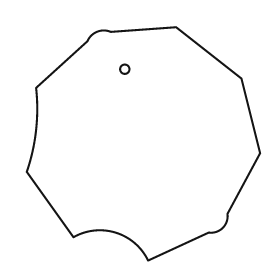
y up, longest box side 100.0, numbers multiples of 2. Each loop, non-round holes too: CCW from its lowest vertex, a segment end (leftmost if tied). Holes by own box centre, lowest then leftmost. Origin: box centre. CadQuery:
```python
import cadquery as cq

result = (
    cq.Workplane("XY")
    .moveTo(2.0, -50.0)
    .lineTo(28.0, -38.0)
    .threePointArc((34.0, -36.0), (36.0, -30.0))
    .lineTo(50.0, -4.0)
    .lineTo(42.0, 28.0)
    .lineTo(14.0, 50.0)
    .lineTo(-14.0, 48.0)
    .threePointArc((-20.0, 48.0), (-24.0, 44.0))
    .lineTo(-46.0, 24.0)
    .threePointArc((-46.0, 6.0), (-50.0, -12.0))
    .lineTo(-30.0, -40.0)
    .threePointArc((-12.0, -38.0), (2.0, -50.0))
    .close()
    .moveTo(-8.0, 32.0)
    .circle(2.0)
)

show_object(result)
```